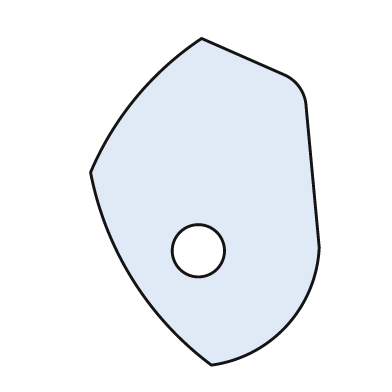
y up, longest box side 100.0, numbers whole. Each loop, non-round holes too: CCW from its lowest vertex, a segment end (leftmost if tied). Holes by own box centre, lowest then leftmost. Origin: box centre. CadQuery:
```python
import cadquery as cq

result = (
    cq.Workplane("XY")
    .moveTo(2.0, -50.0)
    .threePointArc((25.0, -38.0), (35.0, -14.0))
    .lineTo(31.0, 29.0)
    .threePointArc((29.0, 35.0), (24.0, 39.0))
    .lineTo(-1.0, 50.0)
    .threePointArc((-21.0, 32.0), (-35.0, 9.0))
    .threePointArc((-22.0, -24.0), (2.0, -50.0))
    .close()
    .moveTo(-2.0, -15.0)
    .circle(8.0)
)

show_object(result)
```